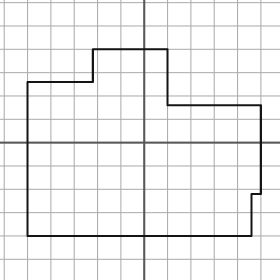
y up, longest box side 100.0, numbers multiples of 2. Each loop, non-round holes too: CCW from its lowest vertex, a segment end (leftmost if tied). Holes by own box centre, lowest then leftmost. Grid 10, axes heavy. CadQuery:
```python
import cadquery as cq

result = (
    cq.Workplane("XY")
    .moveTo(-50.0, -40.0)
    .lineTo(46.0, -40.0)
    .lineTo(46.0, -22.0)
    .lineTo(50.0, -22.0)
    .lineTo(50.0, 16.0)
    .lineTo(10.0, 16.0)
    .lineTo(10.0, 40.0)
    .lineTo(-22.0, 40.0)
    .lineTo(-22.0, 26.0)
    .lineTo(-50.0, 26.0)
    .close()
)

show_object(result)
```